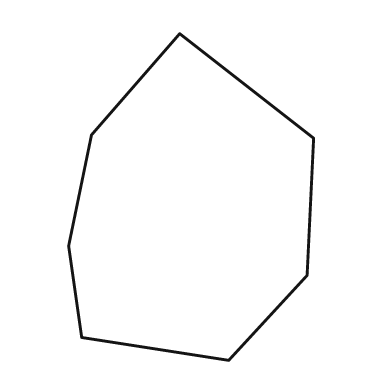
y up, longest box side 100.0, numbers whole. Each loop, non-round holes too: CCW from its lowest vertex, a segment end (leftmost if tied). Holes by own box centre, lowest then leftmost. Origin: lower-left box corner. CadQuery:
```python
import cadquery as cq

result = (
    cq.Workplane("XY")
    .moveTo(49.0, 0.0)
    .lineTo(73.0, 26.0)
    .lineTo(75.0, 68.0)
    .lineTo(34.0, 100.0)
    .lineTo(7.0, 69.0)
    .lineTo(0.0, 35.0)
    .lineTo(4.0, 7.0)
    .close()
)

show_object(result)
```